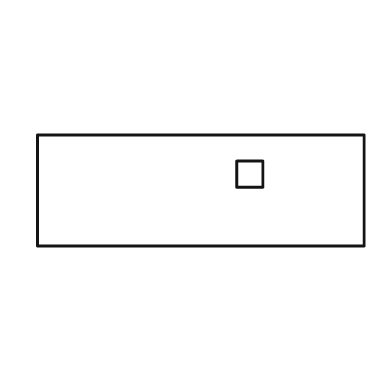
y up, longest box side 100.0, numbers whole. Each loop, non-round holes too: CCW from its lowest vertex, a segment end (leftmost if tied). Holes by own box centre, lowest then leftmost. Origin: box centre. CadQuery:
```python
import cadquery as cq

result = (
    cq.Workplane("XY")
    .moveTo(-50.0, -17.0)
    .lineTo(50.0, -17.0)
    .lineTo(50.0, 17.0)
    .lineTo(-50.0, 17.0)
    .close()
    .moveTo(11.0, 1.0)
    .lineTo(19.0, 1.0)
    .lineTo(19.0, 9.0)
    .lineTo(11.0, 9.0)
    .close()
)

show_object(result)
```